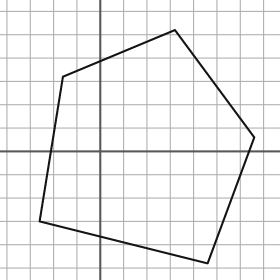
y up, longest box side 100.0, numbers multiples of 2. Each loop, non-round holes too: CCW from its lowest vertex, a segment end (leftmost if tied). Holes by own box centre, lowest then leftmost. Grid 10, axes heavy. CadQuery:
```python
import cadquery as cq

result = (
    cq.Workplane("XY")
    .moveTo(46.0, -48.0)
    .lineTo(66.0, 6.0)
    .lineTo(32.0, 52.0)
    .lineTo(-16.0, 32.0)
    .lineTo(-26.0, -30.0)
    .close()
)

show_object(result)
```